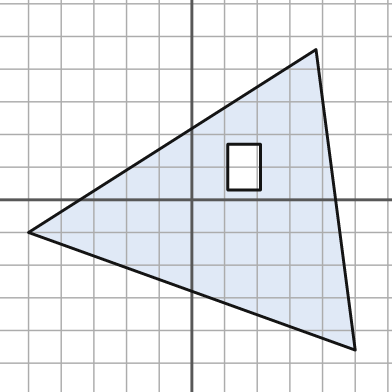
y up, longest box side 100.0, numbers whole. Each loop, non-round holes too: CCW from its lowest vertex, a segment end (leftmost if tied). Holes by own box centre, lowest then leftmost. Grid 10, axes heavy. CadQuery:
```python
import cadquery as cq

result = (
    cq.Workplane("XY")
    .moveTo(50.0, -46.0)
    .lineTo(38.0, 46.0)
    .lineTo(-50.0, -10.0)
    .close()
    .moveTo(11.0, 3.0)
    .lineTo(21.0, 3.0)
    .lineTo(21.0, 17.0)
    .lineTo(11.0, 17.0)
    .close()
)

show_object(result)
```